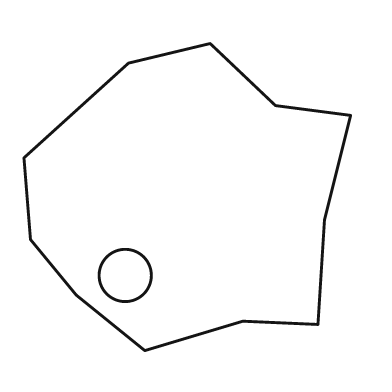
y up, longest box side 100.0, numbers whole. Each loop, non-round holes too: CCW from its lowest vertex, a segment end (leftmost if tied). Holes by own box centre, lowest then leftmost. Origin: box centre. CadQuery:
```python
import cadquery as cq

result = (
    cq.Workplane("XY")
    .moveTo(-13.0, -47.0)
    .lineTo(17.0, -38.0)
    .lineTo(40.0, -39.0)
    .lineTo(42.0, -7.0)
    .lineTo(50.0, 25.0)
    .lineTo(27.0, 28.0)
    .lineTo(7.0, 47.0)
    .lineTo(-18.0, 41.0)
    .lineTo(-50.0, 12.0)
    .lineTo(-48.0, -13.0)
    .lineTo(-34.0, -30.0)
    .close()
    .moveTo(-19.0, -24.0)
    .circle(8.0)
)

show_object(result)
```